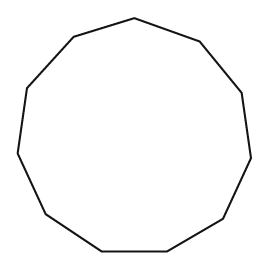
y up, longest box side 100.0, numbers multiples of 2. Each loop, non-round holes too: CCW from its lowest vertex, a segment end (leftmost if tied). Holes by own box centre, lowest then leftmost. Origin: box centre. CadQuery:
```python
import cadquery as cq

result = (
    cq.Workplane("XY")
    .moveTo(-14.0, -50.0)
    .lineTo(14.0, -50.0)
    .lineTo(38.0, -36.0)
    .lineTo(50.0, -10.0)
    .lineTo(46.0, 18.0)
    .lineTo(28.0, 40.0)
    .lineTo(0.0, 50.0)
    .lineTo(-26.0, 42.0)
    .lineTo(-46.0, 20.0)
    .lineTo(-50.0, -8.0)
    .lineTo(-38.0, -34.0)
    .close()
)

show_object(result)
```